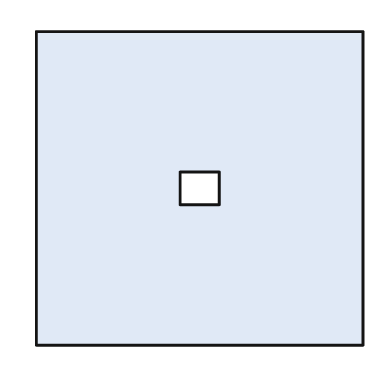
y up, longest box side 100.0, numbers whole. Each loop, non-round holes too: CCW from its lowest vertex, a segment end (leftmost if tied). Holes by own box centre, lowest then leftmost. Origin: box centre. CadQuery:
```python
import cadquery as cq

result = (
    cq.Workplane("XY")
    .moveTo(-50.0, -48.0)
    .lineTo(50.0, -48.0)
    .lineTo(50.0, 48.0)
    .lineTo(-50.0, 48.0)
    .close()
    .moveTo(-6.0, -5.0)
    .lineTo(6.0, -5.0)
    .lineTo(6.0, 5.0)
    .lineTo(-6.0, 5.0)
    .close()
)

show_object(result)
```